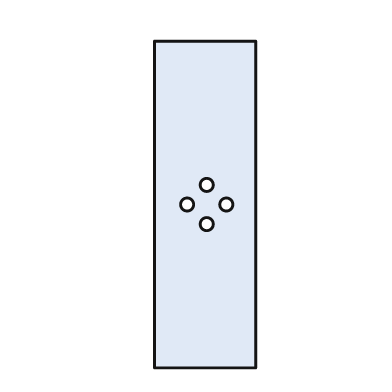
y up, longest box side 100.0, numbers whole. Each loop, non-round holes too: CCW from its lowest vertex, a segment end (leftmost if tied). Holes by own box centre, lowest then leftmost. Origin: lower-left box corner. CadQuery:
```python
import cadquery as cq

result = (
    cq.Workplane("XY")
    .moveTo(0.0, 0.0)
    .lineTo(31.0, 0.0)
    .lineTo(31.0, 100.0)
    .lineTo(0.0, 100.0)
    .close()
    .moveTo(16.0, 44.0)
    .circle(2.0)
    .moveTo(10.0, 50.0)
    .circle(2.0)
    .moveTo(22.0, 50.0)
    .circle(2.0)
    .moveTo(16.0, 56.0)
    .circle(2.0)
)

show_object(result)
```